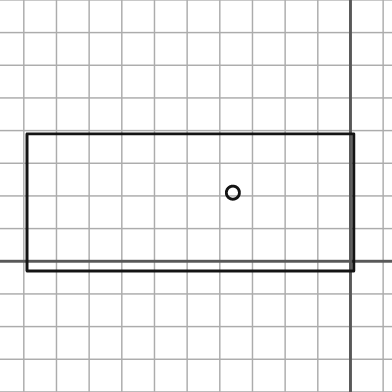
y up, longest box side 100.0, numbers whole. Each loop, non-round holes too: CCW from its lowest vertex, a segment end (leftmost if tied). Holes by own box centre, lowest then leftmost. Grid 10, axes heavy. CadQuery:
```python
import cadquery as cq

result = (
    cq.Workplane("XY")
    .moveTo(-99.0, -3.0)
    .lineTo(1.0, -3.0)
    .lineTo(1.0, 39.0)
    .lineTo(-99.0, 39.0)
    .close()
    .moveTo(-36.0, 21.0)
    .circle(2.0)
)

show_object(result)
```